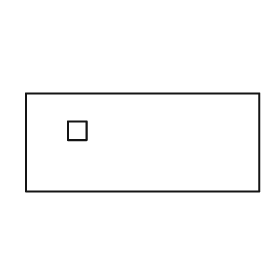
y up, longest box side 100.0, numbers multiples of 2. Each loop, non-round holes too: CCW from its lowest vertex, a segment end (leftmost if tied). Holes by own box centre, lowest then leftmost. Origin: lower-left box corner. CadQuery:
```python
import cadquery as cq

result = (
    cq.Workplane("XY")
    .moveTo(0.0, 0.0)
    .lineTo(100.0, 0.0)
    .lineTo(100.0, 42.0)
    .lineTo(0.0, 42.0)
    .close()
    .moveTo(18.0, 22.0)
    .lineTo(26.0, 22.0)
    .lineTo(26.0, 30.0)
    .lineTo(18.0, 30.0)
    .close()
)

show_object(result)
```